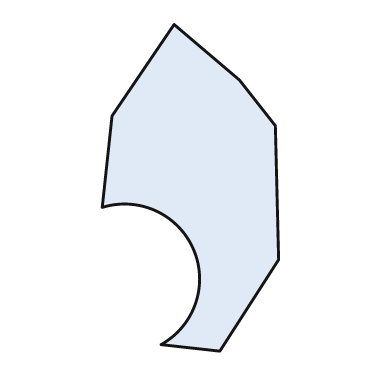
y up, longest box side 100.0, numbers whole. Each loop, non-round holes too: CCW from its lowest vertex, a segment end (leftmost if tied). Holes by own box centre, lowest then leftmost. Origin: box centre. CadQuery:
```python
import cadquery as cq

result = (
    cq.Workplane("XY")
    .moveTo(9.0, -50.0)
    .lineTo(27.0, -22.0)
    .lineTo(26.0, 19.0)
    .lineTo(15.0, 33.0)
    .lineTo(-5.0, 50.0)
    .lineTo(-24.0, 22.0)
    .lineTo(-27.0, -6.0)
    .threePointArc((1.0, -19.0), (-9.0, -48.0))
    .close()
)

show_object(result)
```